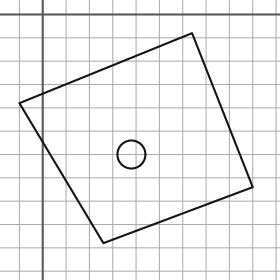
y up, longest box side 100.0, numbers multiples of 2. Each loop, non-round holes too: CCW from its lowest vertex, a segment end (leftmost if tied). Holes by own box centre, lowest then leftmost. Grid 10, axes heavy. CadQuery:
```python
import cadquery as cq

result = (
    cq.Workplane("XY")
    .moveTo(26.0, -98.0)
    .lineTo(90.0, -74.0)
    .lineTo(64.0, -8.0)
    .lineTo(-10.0, -38.0)
    .close()
    .moveTo(38.0, -60.0)
    .circle(6.0)
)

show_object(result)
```